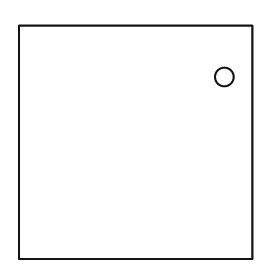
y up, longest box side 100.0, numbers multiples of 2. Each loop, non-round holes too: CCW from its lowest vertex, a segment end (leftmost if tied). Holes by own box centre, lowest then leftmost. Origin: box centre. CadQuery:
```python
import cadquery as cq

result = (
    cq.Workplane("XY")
    .moveTo(-50.0, -50.0)
    .lineTo(50.0, -50.0)
    .lineTo(50.0, 50.0)
    .lineTo(-50.0, 50.0)
    .close()
    .moveTo(38.0, 28.0)
    .circle(4.0)
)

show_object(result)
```